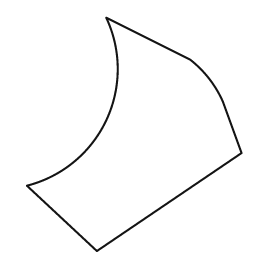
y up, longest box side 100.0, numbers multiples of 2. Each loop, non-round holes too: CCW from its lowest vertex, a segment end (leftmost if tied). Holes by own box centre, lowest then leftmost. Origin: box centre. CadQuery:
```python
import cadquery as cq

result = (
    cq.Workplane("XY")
    .moveTo(-16.0, -50.0)
    .lineTo(46.0, -8.0)
    .lineTo(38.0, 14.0)
    .threePointArc((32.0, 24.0), (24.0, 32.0))
    .lineTo(-12.0, 50.0)
    .threePointArc((-12.0, 6.0), (-46.0, -22.0))
    .close()
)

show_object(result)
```